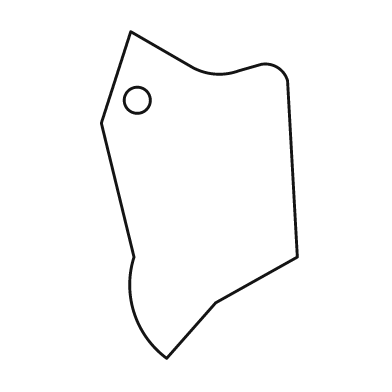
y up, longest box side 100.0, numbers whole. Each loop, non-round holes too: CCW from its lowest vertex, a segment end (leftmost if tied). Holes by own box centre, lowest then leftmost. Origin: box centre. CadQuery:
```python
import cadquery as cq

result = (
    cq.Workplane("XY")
    .moveTo(-10.0, -50.0)
    .lineTo(5.0, -33.0)
    .lineTo(30.0, -19.0)
    .lineTo(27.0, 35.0)
    .threePointArc((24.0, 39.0), (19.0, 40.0))
    .lineTo(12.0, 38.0)
    .threePointArc((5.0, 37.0), (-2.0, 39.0))
    .lineTo(-21.0, 50.0)
    .lineTo(-30.0, 22.0)
    .lineTo(-20.0, -19.0)
    .threePointArc((-20.0, -36.0), (-10.0, -50.0))
    .close()
    .moveTo(-19.0, 29.0)
    .circle(4.0)
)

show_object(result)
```